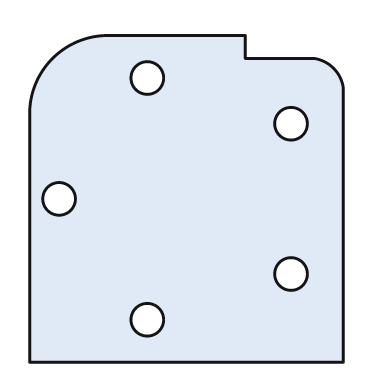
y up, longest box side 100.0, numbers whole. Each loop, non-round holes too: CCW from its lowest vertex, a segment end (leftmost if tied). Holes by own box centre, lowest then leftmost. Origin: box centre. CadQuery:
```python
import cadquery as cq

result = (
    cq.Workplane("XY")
    .moveTo(-48.0, -50.0)
    .lineTo(48.0, -50.0)
    .lineTo(48.0, 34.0)
    .threePointArc((45.0, 40.0), (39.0, 43.0))
    .lineTo(18.0, 43.0)
    .lineTo(18.0, 50.0)
    .lineTo(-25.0, 50.0)
    .threePointArc((-41.0, 43.0), (-48.0, 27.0))
    .close()
    .moveTo(-12.0, -37.0)
    .circle(5.0)
    .moveTo(32.0, -23.0)
    .circle(5.0)
    .moveTo(-39.0, 0.0)
    .circle(5.0)
    .moveTo(32.0, 23.0)
    .circle(5.0)
    .moveTo(-12.0, 37.0)
    .circle(5.0)
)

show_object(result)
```